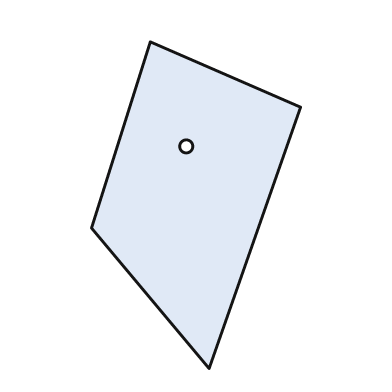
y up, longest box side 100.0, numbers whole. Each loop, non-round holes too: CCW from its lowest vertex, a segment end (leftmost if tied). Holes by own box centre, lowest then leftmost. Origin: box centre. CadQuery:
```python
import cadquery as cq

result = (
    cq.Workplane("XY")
    .moveTo(4.0, -50.0)
    .lineTo(32.0, 30.0)
    .lineTo(-14.0, 50.0)
    .lineTo(-32.0, -7.0)
    .close()
    .moveTo(-3.0, 18.0)
    .circle(2.0)
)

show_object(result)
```